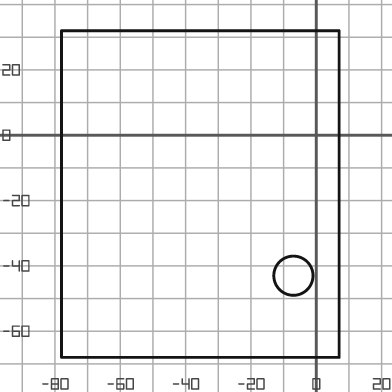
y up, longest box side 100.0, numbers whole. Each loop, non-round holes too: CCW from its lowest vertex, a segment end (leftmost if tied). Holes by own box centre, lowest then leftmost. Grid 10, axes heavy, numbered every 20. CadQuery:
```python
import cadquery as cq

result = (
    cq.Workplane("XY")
    .moveTo(-78.0, -68.0)
    .lineTo(7.0, -68.0)
    .lineTo(7.0, 32.0)
    .lineTo(-78.0, 32.0)
    .close()
    .moveTo(-7.0, -43.0)
    .circle(6.0)
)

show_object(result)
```